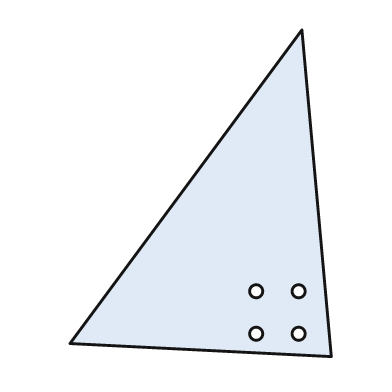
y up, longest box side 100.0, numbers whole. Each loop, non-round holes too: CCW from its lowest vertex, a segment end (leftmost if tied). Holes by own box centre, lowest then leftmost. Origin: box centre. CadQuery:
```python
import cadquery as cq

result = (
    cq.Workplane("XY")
    .moveTo(40.0, -50.0)
    .lineTo(31.0, 50.0)
    .lineTo(-40.0, -46.0)
    .close()
    .moveTo(17.0, -43.0)
    .circle(2.0)
    .moveTo(30.0, -43.0)
    .circle(2.0)
    .moveTo(17.0, -30.0)
    .circle(2.0)
    .moveTo(30.0, -30.0)
    .circle(2.0)
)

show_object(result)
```